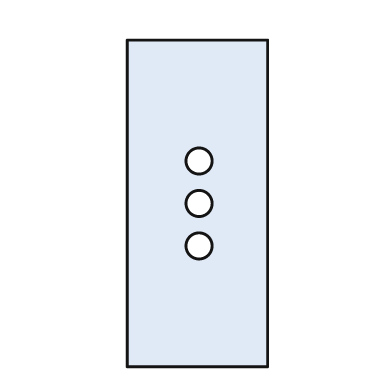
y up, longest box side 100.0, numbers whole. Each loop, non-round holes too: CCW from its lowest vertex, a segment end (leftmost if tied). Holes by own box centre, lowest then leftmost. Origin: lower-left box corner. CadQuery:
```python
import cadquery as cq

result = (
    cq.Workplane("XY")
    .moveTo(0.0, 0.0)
    .lineTo(43.0, 0.0)
    .lineTo(43.0, 100.0)
    .lineTo(0.0, 100.0)
    .close()
    .moveTo(22.0, 37.0)
    .circle(4.0)
    .moveTo(22.0, 50.0)
    .circle(4.0)
    .moveTo(22.0, 63.0)
    .circle(4.0)
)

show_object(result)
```